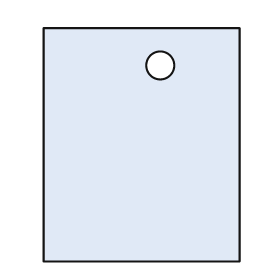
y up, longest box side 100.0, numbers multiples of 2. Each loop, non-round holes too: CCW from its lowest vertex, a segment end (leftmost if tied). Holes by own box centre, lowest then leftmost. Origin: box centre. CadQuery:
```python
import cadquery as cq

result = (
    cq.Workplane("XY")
    .moveTo(-42.0, -50.0)
    .lineTo(42.0, -50.0)
    .lineTo(42.0, 50.0)
    .lineTo(-42.0, 50.0)
    .close()
    .moveTo(8.0, 34.0)
    .circle(6.0)
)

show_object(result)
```